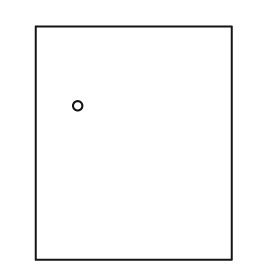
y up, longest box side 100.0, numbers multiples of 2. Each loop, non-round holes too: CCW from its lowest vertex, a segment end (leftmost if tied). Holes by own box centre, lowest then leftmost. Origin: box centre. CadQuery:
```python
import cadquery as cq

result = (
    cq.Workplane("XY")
    .moveTo(-42.0, -50.0)
    .lineTo(42.0, -50.0)
    .lineTo(42.0, 50.0)
    .lineTo(-42.0, 50.0)
    .close()
    .moveTo(-24.0, 16.0)
    .circle(2.0)
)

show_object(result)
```